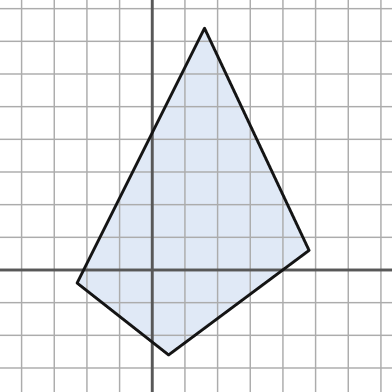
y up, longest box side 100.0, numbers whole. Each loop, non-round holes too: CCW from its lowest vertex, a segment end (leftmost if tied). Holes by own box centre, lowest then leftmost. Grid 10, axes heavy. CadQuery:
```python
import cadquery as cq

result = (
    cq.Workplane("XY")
    .moveTo(5.0, -26.0)
    .lineTo(48.0, 6.0)
    .lineTo(16.0, 74.0)
    .lineTo(-23.0, -4.0)
    .close()
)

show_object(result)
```